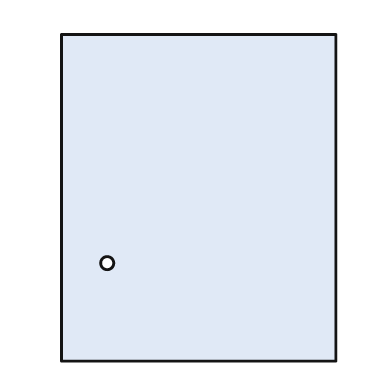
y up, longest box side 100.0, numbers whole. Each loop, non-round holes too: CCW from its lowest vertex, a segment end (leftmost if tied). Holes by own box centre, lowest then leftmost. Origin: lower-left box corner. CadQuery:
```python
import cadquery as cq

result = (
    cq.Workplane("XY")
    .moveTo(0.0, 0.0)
    .lineTo(84.0, 0.0)
    .lineTo(84.0, 100.0)
    .lineTo(0.0, 100.0)
    .close()
    .moveTo(14.0, 30.0)
    .circle(2.0)
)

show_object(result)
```